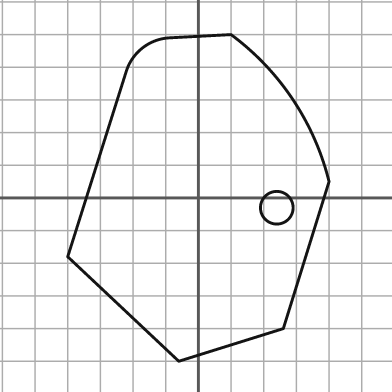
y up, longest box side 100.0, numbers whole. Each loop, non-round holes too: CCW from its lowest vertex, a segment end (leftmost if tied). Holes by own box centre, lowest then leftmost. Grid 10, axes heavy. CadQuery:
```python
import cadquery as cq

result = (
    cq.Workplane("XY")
    .moveTo(-6.0, -50.0)
    .lineTo(26.0, -40.0)
    .lineTo(40.0, 5.0)
    .threePointArc((29.0, 30.0), (10.0, 50.0))
    .lineTo(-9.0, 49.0)
    .threePointArc((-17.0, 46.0), (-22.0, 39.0))
    .lineTo(-40.0, -18.0)
    .close()
    .moveTo(24.0, -3.0)
    .circle(5.0)
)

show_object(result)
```